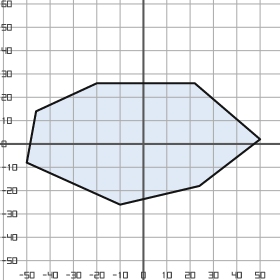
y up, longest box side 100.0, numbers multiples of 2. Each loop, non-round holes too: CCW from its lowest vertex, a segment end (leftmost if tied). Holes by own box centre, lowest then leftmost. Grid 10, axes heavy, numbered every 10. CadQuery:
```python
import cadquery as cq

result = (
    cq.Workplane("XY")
    .moveTo(-10.0, -26.0)
    .lineTo(24.0, -18.0)
    .lineTo(50.0, 2.0)
    .lineTo(22.0, 26.0)
    .lineTo(-20.0, 26.0)
    .lineTo(-46.0, 14.0)
    .lineTo(-50.0, -8.0)
    .close()
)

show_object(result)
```